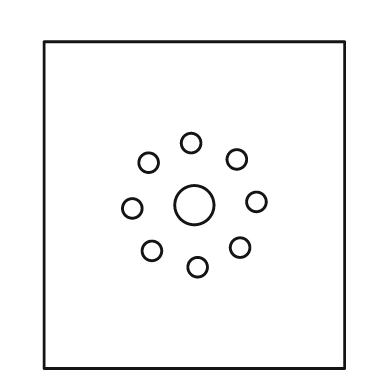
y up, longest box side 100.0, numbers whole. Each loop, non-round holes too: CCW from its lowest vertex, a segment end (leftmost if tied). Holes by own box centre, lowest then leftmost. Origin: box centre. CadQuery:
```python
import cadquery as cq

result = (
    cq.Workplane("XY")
    .moveTo(-46.0, -50.0)
    .lineTo(46.0, -50.0)
    .lineTo(46.0, 50.0)
    .lineTo(-46.0, 50.0)
    .close()
    .moveTo(1.0, -19.0)
    .circle(3.0)
    .moveTo(-13.0, -14.0)
    .circle(3.0)
    .moveTo(14.0, -13.0)
    .circle(3.0)
    .moveTo(-19.0, -1.0)
    .circle(3.0)
    .moveTo(0.0, 0.0)
    .circle(6.0)
    .moveTo(19.0, 1.0)
    .circle(3.0)
    .moveTo(-14.0, 13.0)
    .circle(3.0)
    .moveTo(13.0, 14.0)
    .circle(3.0)
    .moveTo(-1.0, 19.0)
    .circle(3.0)
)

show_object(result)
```